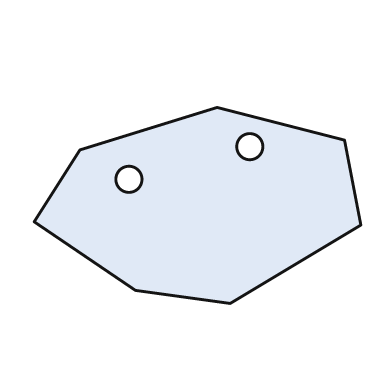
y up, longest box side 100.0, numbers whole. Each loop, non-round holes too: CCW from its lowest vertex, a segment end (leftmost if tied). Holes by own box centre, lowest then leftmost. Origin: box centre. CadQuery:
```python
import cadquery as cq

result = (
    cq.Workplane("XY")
    .moveTo(10.0, -30.0)
    .lineTo(50.0, -6.0)
    .lineTo(45.0, 20.0)
    .lineTo(6.0, 30.0)
    .lineTo(-36.0, 17.0)
    .lineTo(-50.0, -5.0)
    .lineTo(-19.0, -26.0)
    .close()
    .moveTo(-21.0, 8.0)
    .circle(4.0)
    .moveTo(16.0, 18.0)
    .circle(4.0)
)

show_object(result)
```